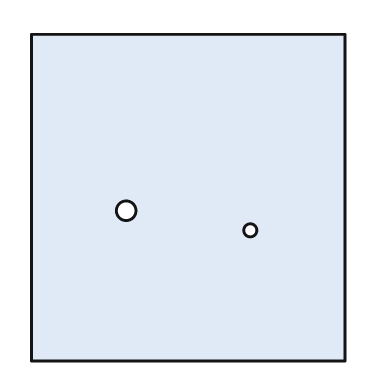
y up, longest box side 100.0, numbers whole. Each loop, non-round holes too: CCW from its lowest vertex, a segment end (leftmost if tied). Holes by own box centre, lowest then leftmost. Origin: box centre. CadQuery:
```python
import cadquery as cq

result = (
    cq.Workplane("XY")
    .moveTo(-48.0, -50.0)
    .lineTo(48.0, -50.0)
    .lineTo(48.0, 50.0)
    .lineTo(-48.0, 50.0)
    .close()
    .moveTo(19.0, -10.0)
    .circle(2.0)
    .moveTo(-19.0, -4.0)
    .circle(3.0)
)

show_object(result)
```